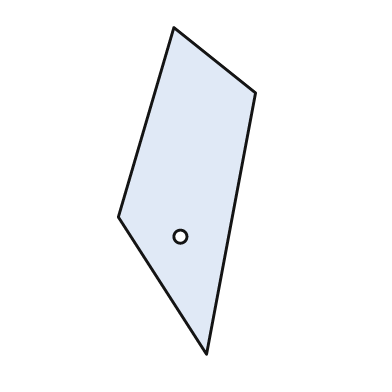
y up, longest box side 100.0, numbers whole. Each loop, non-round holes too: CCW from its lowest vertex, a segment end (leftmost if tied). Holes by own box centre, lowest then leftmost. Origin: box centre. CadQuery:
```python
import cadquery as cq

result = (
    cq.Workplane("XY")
    .moveTo(6.0, -50.0)
    .lineTo(21.0, 30.0)
    .lineTo(-4.0, 50.0)
    .lineTo(-21.0, -8.0)
    .close()
    .moveTo(-2.0, -14.0)
    .circle(2.0)
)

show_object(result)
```